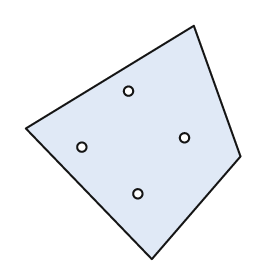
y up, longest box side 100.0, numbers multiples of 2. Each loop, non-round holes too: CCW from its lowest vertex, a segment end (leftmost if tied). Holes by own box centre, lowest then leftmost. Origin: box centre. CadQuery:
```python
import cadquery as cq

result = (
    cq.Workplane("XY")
    .moveTo(8.0, -50.0)
    .lineTo(46.0, -6.0)
    .lineTo(26.0, 50.0)
    .lineTo(-46.0, 6.0)
    .close()
    .moveTo(2.0, -22.0)
    .circle(2.0)
    .moveTo(-22.0, -2.0)
    .circle(2.0)
    .moveTo(22.0, 2.0)
    .circle(2.0)
    .moveTo(-2.0, 22.0)
    .circle(2.0)
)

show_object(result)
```